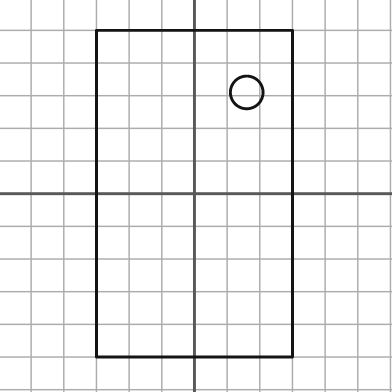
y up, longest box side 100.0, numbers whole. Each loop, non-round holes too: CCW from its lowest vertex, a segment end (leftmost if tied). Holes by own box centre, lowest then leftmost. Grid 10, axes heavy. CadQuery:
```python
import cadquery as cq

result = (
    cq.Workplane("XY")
    .moveTo(-30.0, -50.0)
    .lineTo(30.0, -50.0)
    .lineTo(30.0, 50.0)
    .lineTo(-30.0, 50.0)
    .close()
    .moveTo(16.0, 31.0)
    .circle(5.0)
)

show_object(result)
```